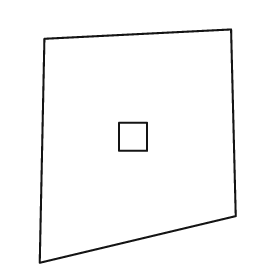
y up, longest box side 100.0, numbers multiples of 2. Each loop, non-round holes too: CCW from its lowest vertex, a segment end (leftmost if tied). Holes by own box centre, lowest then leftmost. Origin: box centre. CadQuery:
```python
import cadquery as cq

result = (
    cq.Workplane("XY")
    .moveTo(-42.0, -50.0)
    .lineTo(42.0, -30.0)
    .lineTo(40.0, 50.0)
    .lineTo(-40.0, 46.0)
    .close()
    .moveTo(-8.0, -2.0)
    .lineTo(4.0, -2.0)
    .lineTo(4.0, 10.0)
    .lineTo(-8.0, 10.0)
    .close()
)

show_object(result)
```